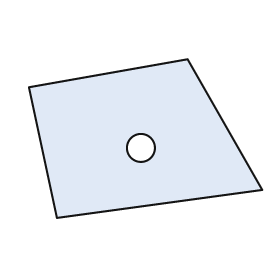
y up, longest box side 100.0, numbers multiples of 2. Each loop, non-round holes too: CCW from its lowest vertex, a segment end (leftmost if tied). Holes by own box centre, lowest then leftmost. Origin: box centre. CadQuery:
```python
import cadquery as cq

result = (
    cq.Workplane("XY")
    .moveTo(-38.0, -34.0)
    .lineTo(50.0, -22.0)
    .lineTo(18.0, 34.0)
    .lineTo(-50.0, 22.0)
    .close()
    .moveTo(-2.0, -4.0)
    .circle(6.0)
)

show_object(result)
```